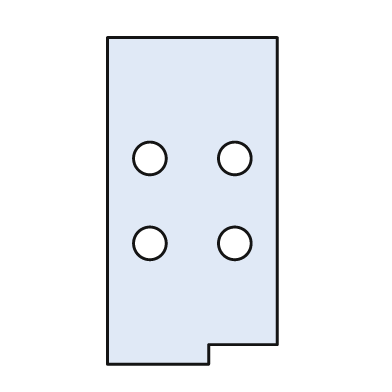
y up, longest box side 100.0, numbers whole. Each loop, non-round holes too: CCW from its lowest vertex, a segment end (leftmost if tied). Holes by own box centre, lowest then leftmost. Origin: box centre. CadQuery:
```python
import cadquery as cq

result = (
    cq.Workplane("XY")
    .moveTo(-26.0, -50.0)
    .lineTo(5.0, -50.0)
    .lineTo(5.0, -44.0)
    .lineTo(26.0, -44.0)
    .lineTo(26.0, 50.0)
    .lineTo(-26.0, 50.0)
    .close()
    .moveTo(-13.0, -13.0)
    .circle(5.0)
    .moveTo(13.0, -13.0)
    .circle(5.0)
    .moveTo(-13.0, 13.0)
    .circle(5.0)
    .moveTo(13.0, 13.0)
    .circle(5.0)
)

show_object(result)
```